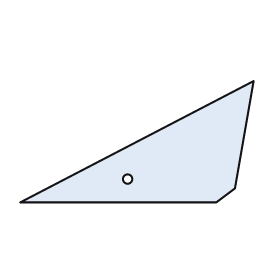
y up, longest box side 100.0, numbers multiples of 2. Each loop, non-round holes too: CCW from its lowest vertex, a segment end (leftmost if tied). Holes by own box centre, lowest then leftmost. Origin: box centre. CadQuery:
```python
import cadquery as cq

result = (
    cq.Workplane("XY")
    .moveTo(-50.0, -26.0)
    .lineTo(34.0, -26.0)
    .lineTo(42.0, -20.0)
    .lineTo(50.0, 26.0)
    .close()
    .moveTo(-4.0, -16.0)
    .circle(2.0)
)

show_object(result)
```